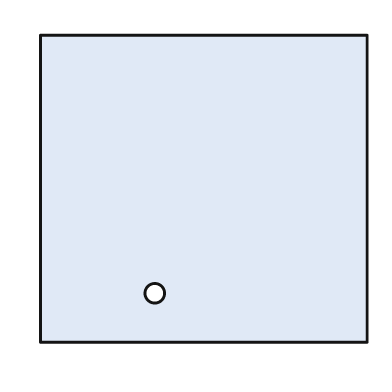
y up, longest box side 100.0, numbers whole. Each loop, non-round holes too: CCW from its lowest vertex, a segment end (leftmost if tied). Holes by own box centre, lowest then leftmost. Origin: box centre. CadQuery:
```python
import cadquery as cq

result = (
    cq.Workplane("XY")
    .moveTo(-50.0, -47.0)
    .lineTo(50.0, -47.0)
    .lineTo(50.0, 47.0)
    .lineTo(-50.0, 47.0)
    .close()
    .moveTo(-15.0, -32.0)
    .circle(3.0)
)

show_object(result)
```